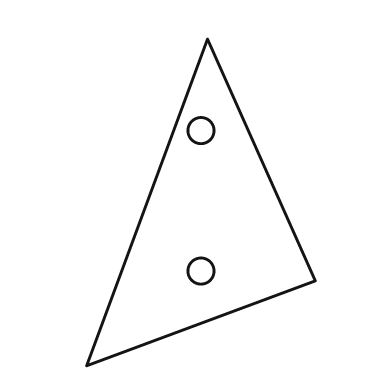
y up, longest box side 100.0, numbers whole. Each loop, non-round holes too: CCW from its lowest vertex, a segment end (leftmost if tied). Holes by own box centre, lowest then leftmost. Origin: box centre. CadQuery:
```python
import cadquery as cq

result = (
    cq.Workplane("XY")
    .moveTo(-35.0, -50.0)
    .lineTo(35.0, -24.0)
    .lineTo(2.0, 50.0)
    .close()
    .moveTo(0.0, -21.0)
    .circle(4.0)
    .moveTo(0.0, 22.0)
    .circle(4.0)
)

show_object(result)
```